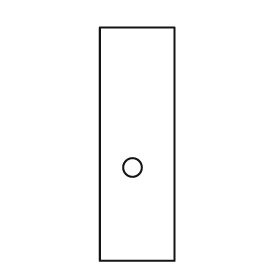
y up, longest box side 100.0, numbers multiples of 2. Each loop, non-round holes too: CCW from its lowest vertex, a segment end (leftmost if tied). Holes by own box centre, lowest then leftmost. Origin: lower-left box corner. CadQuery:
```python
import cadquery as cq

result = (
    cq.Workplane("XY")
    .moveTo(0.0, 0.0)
    .lineTo(32.0, 0.0)
    .lineTo(32.0, 100.0)
    .lineTo(0.0, 100.0)
    .close()
    .moveTo(14.0, 40.0)
    .circle(4.0)
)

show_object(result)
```